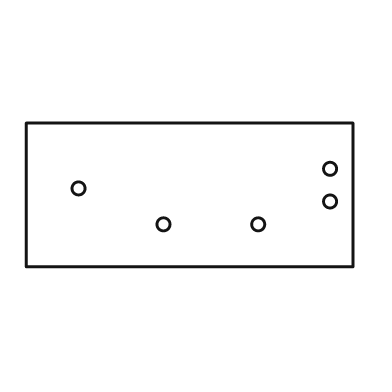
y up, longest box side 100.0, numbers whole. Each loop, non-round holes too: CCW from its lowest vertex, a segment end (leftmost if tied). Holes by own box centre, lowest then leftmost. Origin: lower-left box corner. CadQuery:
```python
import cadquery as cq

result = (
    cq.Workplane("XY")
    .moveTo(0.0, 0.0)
    .lineTo(100.0, 0.0)
    .lineTo(100.0, 44.0)
    .lineTo(0.0, 44.0)
    .close()
    .moveTo(42.0, 13.0)
    .circle(2.0)
    .moveTo(71.0, 13.0)
    .circle(2.0)
    .moveTo(93.0, 20.0)
    .circle(2.0)
    .moveTo(16.0, 24.0)
    .circle(2.0)
    .moveTo(93.0, 30.0)
    .circle(2.0)
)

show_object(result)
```